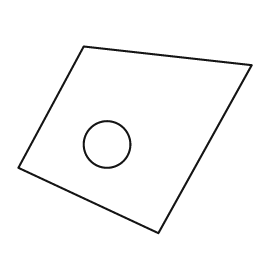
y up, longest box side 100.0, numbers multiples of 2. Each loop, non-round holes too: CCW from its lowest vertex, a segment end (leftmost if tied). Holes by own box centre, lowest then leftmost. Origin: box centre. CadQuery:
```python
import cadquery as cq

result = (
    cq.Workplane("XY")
    .moveTo(10.0, -40.0)
    .lineTo(50.0, 32.0)
    .lineTo(-22.0, 40.0)
    .lineTo(-50.0, -12.0)
    .close()
    .moveTo(-12.0, -2.0)
    .circle(10.0)
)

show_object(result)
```